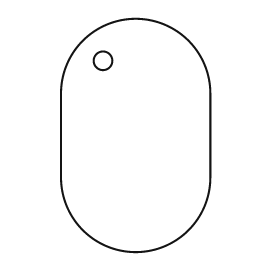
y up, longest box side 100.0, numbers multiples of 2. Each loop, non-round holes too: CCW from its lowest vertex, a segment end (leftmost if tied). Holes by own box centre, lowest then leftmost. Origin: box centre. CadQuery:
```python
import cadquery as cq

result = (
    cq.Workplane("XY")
    .moveTo(-32.0, -18.0)
    .threePointArc((0.0, -50.0), (32.0, -18.0))
    .lineTo(32.0, 18.0)
    .threePointArc((0.0, 50.0), (-32.0, 18.0))
    .close()
    .moveTo(-14.0, 32.0)
    .circle(4.0)
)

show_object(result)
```